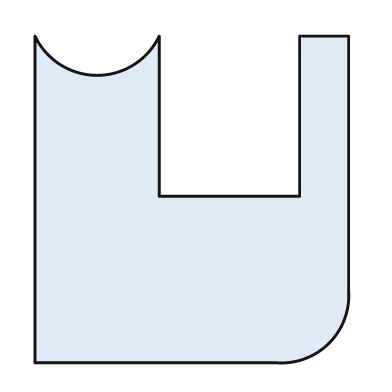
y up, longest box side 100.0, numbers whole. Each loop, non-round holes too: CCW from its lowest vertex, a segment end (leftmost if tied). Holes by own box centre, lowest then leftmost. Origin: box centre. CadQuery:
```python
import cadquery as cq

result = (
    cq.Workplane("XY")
    .moveTo(-48.0, -50.0)
    .lineTo(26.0, -50.0)
    .threePointArc((42.0, -44.0), (48.0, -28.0))
    .lineTo(48.0, 50.0)
    .lineTo(33.0, 50.0)
    .lineTo(33.0, 1.0)
    .lineTo(-10.0, 1.0)
    .lineTo(-10.0, 50.0)
    .threePointArc((-29.0, 38.0), (-48.0, 50.0))
    .close()
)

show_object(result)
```